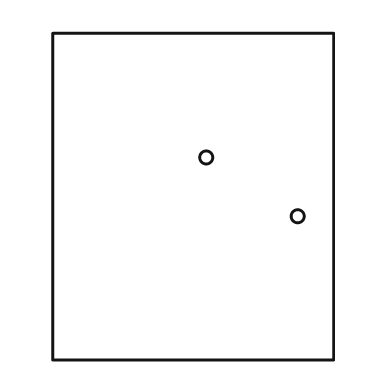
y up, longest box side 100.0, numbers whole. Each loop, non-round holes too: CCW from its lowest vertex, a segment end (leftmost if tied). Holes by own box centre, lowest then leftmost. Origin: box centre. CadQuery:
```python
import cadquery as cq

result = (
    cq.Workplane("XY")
    .moveTo(-43.0, -50.0)
    .lineTo(43.0, -50.0)
    .lineTo(43.0, 50.0)
    .lineTo(-43.0, 50.0)
    .close()
    .moveTo(32.0, -6.0)
    .circle(2.0)
    .moveTo(4.0, 12.0)
    .circle(2.0)
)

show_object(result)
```